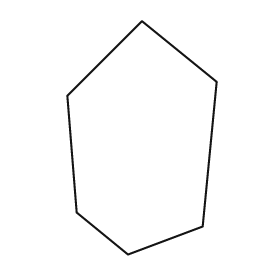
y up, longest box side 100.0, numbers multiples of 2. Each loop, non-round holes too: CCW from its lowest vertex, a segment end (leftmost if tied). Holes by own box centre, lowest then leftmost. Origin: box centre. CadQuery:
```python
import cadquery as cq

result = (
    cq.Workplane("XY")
    .moveTo(-6.0, -50.0)
    .lineTo(26.0, -38.0)
    .lineTo(32.0, 24.0)
    .lineTo(0.0, 50.0)
    .lineTo(-32.0, 18.0)
    .lineTo(-28.0, -32.0)
    .close()
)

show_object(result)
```